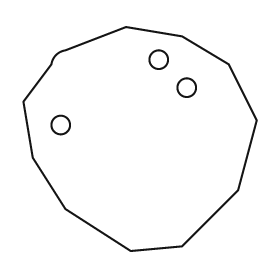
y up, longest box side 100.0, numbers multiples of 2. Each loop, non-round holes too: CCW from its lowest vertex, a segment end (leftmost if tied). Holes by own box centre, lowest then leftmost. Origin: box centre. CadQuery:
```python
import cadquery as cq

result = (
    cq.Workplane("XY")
    .moveTo(-4.0, -48.0)
    .lineTo(18.0, -46.0)
    .lineTo(42.0, -22.0)
    .lineTo(50.0, 8.0)
    .lineTo(38.0, 32.0)
    .lineTo(18.0, 44.0)
    .lineTo(-6.0, 48.0)
    .lineTo(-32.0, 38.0)
    .threePointArc((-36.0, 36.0), (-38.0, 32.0))
    .lineTo(-50.0, 16.0)
    .lineTo(-46.0, -8.0)
    .lineTo(-32.0, -30.0)
    .close()
    .moveTo(-34.0, 6.0)
    .circle(4.0)
    .moveTo(20.0, 22.0)
    .circle(4.0)
    .moveTo(8.0, 34.0)
    .circle(4.0)
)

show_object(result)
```